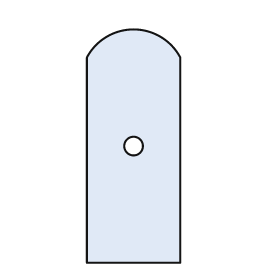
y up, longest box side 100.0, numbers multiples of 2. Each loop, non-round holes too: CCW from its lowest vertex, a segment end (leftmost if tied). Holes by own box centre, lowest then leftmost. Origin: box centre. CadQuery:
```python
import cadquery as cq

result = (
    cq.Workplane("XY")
    .moveTo(-20.0, -50.0)
    .lineTo(20.0, -50.0)
    .lineTo(20.0, 38.0)
    .threePointArc((0.0, 50.0), (-20.0, 38.0))
    .close()
    .moveTo(0.0, 0.0)
    .circle(4.0)
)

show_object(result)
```